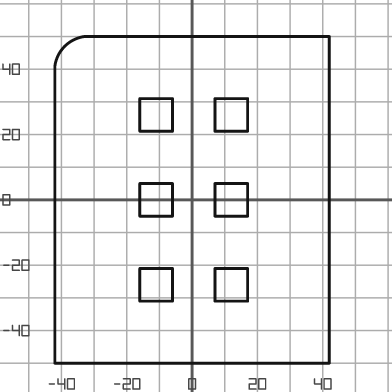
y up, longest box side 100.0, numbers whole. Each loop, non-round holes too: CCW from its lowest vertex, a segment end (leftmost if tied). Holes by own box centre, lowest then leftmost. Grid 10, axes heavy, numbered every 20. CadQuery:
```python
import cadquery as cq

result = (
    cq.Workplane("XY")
    .moveTo(-42.0, -50.0)
    .lineTo(42.0, -50.0)
    .lineTo(42.0, 50.0)
    .lineTo(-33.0, 50.0)
    .threePointArc((-39.0, 47.0), (-42.0, 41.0))
    .close()
    .moveTo(-16.0, -31.0)
    .lineTo(-6.0, -31.0)
    .lineTo(-6.0, -21.0)
    .lineTo(-16.0, -21.0)
    .close()
    .moveTo(7.0, -31.0)
    .lineTo(17.0, -31.0)
    .lineTo(17.0, -21.0)
    .lineTo(7.0, -21.0)
    .close()
    .moveTo(-16.0, -5.0)
    .lineTo(-6.0, -5.0)
    .lineTo(-6.0, 5.0)
    .lineTo(-16.0, 5.0)
    .close()
    .moveTo(7.0, -5.0)
    .lineTo(17.0, -5.0)
    .lineTo(17.0, 5.0)
    .lineTo(7.0, 5.0)
    .close()
    .moveTo(-16.0, 21.0)
    .lineTo(-6.0, 21.0)
    .lineTo(-6.0, 31.0)
    .lineTo(-16.0, 31.0)
    .close()
    .moveTo(7.0, 21.0)
    .lineTo(17.0, 21.0)
    .lineTo(17.0, 31.0)
    .lineTo(7.0, 31.0)
    .close()
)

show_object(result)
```